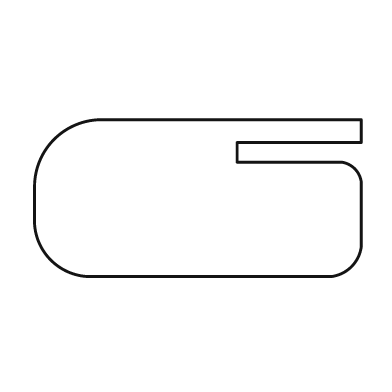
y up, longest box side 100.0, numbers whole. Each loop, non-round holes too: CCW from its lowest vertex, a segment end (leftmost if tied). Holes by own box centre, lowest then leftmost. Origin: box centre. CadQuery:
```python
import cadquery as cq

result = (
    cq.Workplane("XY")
    .moveTo(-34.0, -24.0)
    .lineTo(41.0, -24.0)
    .threePointArc((47.0, -21.0), (50.0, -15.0))
    .lineTo(50.0, 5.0)
    .threePointArc((48.0, 9.0), (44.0, 11.0))
    .lineTo(12.0, 11.0)
    .lineTo(12.0, 17.0)
    .lineTo(50.0, 17.0)
    .lineTo(50.0, 24.0)
    .lineTo(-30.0, 24.0)
    .threePointArc((-44.0, 18.0), (-50.0, 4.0))
    .lineTo(-50.0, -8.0)
    .threePointArc((-45.0, -19.0), (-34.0, -24.0))
    .close()
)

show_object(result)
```